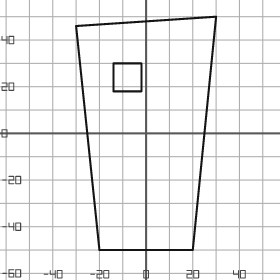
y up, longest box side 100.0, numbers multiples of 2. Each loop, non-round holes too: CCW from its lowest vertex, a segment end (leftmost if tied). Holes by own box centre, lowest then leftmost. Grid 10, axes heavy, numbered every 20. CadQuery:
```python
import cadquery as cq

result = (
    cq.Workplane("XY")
    .moveTo(-20.0, -50.0)
    .lineTo(20.0, -50.0)
    .lineTo(30.0, 50.0)
    .lineTo(-30.0, 46.0)
    .close()
    .moveTo(-14.0, 18.0)
    .lineTo(-2.0, 18.0)
    .lineTo(-2.0, 30.0)
    .lineTo(-14.0, 30.0)
    .close()
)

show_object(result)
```